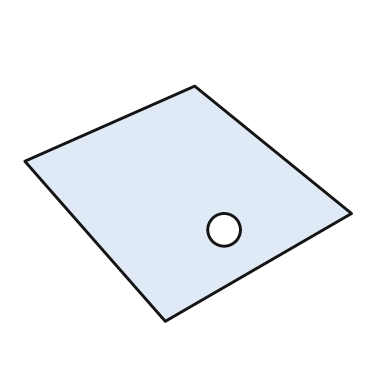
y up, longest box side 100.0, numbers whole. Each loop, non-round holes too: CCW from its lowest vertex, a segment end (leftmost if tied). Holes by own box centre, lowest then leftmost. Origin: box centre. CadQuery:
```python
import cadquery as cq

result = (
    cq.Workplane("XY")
    .moveTo(-7.0, -36.0)
    .lineTo(50.0, -3.0)
    .lineTo(2.0, 36.0)
    .lineTo(-50.0, 13.0)
    .close()
    .moveTo(11.0, -8.0)
    .circle(5.0)
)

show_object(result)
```